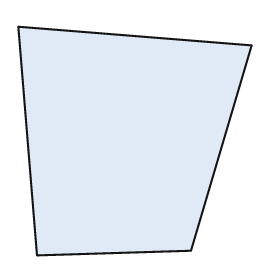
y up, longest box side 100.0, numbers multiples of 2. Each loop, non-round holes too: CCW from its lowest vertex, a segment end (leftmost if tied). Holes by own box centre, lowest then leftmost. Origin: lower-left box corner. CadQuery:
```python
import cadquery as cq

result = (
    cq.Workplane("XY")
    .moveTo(8.0, 0.0)
    .lineTo(74.0, 2.0)
    .lineTo(100.0, 90.0)
    .lineTo(0.0, 98.0)
    .close()
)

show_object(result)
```